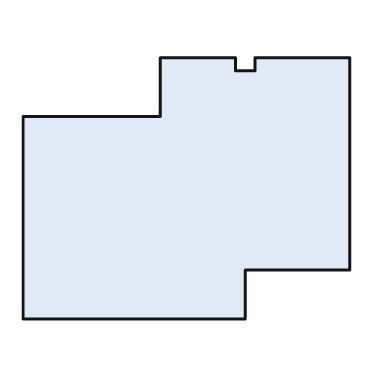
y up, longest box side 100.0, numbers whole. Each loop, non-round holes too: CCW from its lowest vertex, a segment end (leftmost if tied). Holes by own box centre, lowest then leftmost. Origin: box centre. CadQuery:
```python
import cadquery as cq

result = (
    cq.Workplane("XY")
    .moveTo(-50.0, -40.0)
    .lineTo(18.0, -40.0)
    .lineTo(18.0, -25.0)
    .lineTo(50.0, -25.0)
    .lineTo(50.0, 40.0)
    .lineTo(21.0, 40.0)
    .lineTo(21.0, 36.0)
    .lineTo(15.0, 36.0)
    .lineTo(15.0, 40.0)
    .lineTo(-8.0, 40.0)
    .lineTo(-8.0, 22.0)
    .lineTo(-50.0, 22.0)
    .close()
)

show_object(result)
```